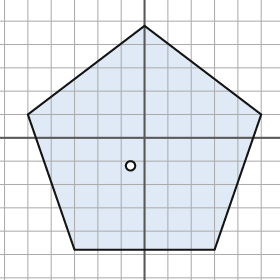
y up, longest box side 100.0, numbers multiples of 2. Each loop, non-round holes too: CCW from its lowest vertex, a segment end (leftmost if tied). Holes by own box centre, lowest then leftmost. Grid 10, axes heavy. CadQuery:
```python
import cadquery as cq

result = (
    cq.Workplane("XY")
    .moveTo(-30.0, -48.0)
    .lineTo(30.0, -48.0)
    .lineTo(50.0, 10.0)
    .lineTo(0.0, 48.0)
    .lineTo(-50.0, 10.0)
    .close()
    .moveTo(-6.0, -12.0)
    .circle(2.0)
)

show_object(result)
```